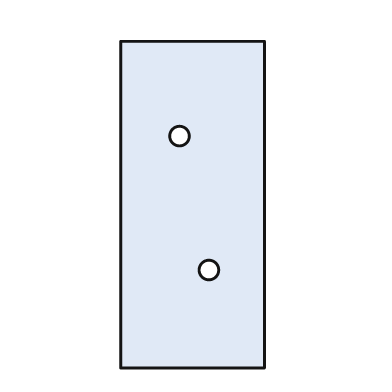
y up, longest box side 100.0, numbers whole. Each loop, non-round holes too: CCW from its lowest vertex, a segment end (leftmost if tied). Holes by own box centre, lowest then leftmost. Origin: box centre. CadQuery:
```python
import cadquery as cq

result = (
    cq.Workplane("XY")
    .moveTo(-22.0, -50.0)
    .lineTo(22.0, -50.0)
    .lineTo(22.0, 50.0)
    .lineTo(-22.0, 50.0)
    .close()
    .moveTo(5.0, -20.0)
    .circle(3.0)
    .moveTo(-4.0, 21.0)
    .circle(3.0)
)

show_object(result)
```